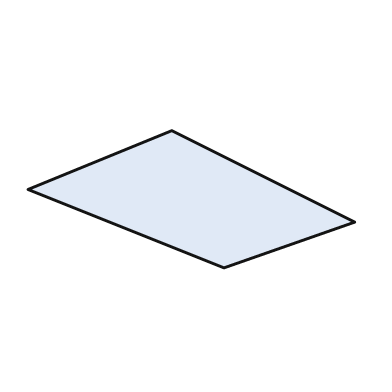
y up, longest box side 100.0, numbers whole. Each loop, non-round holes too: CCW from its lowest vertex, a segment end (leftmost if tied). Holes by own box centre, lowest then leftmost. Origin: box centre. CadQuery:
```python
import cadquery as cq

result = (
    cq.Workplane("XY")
    .moveTo(10.0, -21.0)
    .lineTo(50.0, -7.0)
    .lineTo(-6.0, 21.0)
    .lineTo(-50.0, 3.0)
    .close()
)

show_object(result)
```